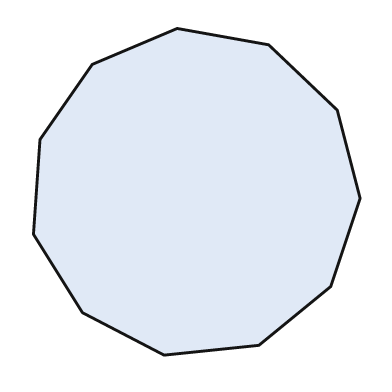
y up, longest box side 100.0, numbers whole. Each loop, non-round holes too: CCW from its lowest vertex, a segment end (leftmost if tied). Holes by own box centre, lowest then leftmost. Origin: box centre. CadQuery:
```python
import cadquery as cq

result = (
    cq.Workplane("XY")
    .moveTo(-10.0, -50.0)
    .lineTo(19.0, -47.0)
    .lineTo(41.0, -29.0)
    .lineTo(50.0, -2.0)
    .lineTo(43.0, 25.0)
    .lineTo(22.0, 45.0)
    .lineTo(-6.0, 50.0)
    .lineTo(-32.0, 39.0)
    .lineTo(-48.0, 16.0)
    .lineTo(-50.0, -13.0)
    .lineTo(-35.0, -37.0)
    .close()
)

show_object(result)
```